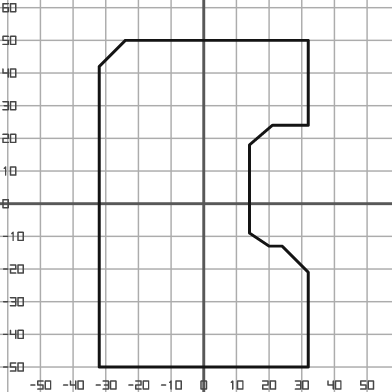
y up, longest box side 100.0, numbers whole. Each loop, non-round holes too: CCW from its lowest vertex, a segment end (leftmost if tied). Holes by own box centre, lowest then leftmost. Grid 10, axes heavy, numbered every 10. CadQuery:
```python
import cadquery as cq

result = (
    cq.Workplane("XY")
    .moveTo(-32.0, -50.0)
    .lineTo(32.0, -50.0)
    .lineTo(32.0, -21.0)
    .lineTo(24.0, -13.0)
    .lineTo(20.0, -13.0)
    .lineTo(14.0, -9.0)
    .lineTo(14.0, 18.0)
    .lineTo(21.0, 24.0)
    .lineTo(32.0, 24.0)
    .lineTo(32.0, 50.0)
    .lineTo(-24.0, 50.0)
    .lineTo(-32.0, 42.0)
    .close()
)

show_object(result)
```